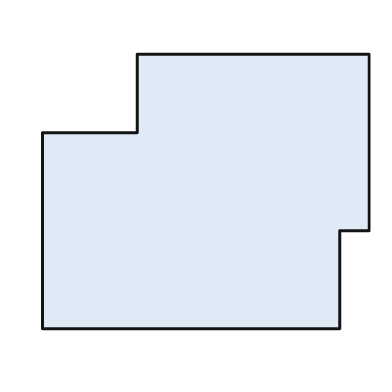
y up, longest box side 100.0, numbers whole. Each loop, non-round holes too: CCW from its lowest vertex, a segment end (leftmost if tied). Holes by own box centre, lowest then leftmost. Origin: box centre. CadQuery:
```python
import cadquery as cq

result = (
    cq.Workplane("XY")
    .moveTo(-50.0, -42.0)
    .lineTo(41.0, -42.0)
    .lineTo(41.0, -12.0)
    .lineTo(50.0, -12.0)
    .lineTo(50.0, 42.0)
    .lineTo(-21.0, 42.0)
    .lineTo(-21.0, 18.0)
    .lineTo(-50.0, 18.0)
    .close()
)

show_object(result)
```